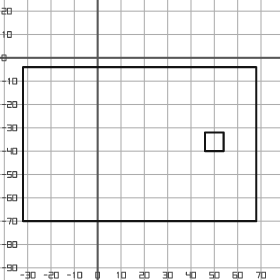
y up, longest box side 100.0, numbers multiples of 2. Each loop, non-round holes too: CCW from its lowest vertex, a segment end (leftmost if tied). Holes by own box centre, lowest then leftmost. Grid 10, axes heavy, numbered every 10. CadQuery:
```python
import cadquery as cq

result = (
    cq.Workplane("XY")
    .moveTo(-32.0, -70.0)
    .lineTo(68.0, -70.0)
    .lineTo(68.0, -4.0)
    .lineTo(-32.0, -4.0)
    .close()
    .moveTo(46.0, -40.0)
    .lineTo(54.0, -40.0)
    .lineTo(54.0, -32.0)
    .lineTo(46.0, -32.0)
    .close()
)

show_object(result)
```